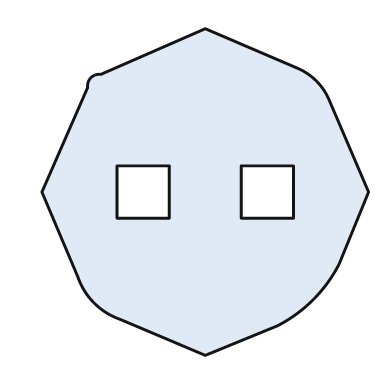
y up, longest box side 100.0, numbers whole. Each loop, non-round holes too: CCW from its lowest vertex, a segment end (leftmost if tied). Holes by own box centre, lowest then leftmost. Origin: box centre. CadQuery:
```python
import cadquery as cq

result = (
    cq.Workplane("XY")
    .moveTo(0.0, -50.0)
    .lineTo(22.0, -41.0)
    .threePointArc((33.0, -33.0), (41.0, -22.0))
    .lineTo(50.0, 0.0)
    .lineTo(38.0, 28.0)
    .threePointArc((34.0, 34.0), (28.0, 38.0))
    .lineTo(0.0, 50.0)
    .lineTo(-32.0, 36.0)
    .threePointArc((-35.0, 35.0), (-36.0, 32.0))
    .lineTo(-50.0, 0.0)
    .lineTo(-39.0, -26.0)
    .threePointArc((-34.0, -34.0), (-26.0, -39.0))
    .close()
    .moveTo(-27.0, -8.0)
    .lineTo(-11.0, -8.0)
    .lineTo(-11.0, 8.0)
    .lineTo(-27.0, 8.0)
    .close()
    .moveTo(11.0, -8.0)
    .lineTo(27.0, -8.0)
    .lineTo(27.0, 8.0)
    .lineTo(11.0, 8.0)
    .close()
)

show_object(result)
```